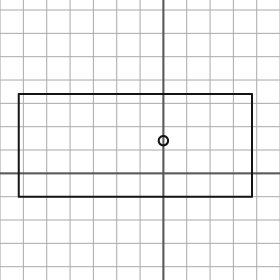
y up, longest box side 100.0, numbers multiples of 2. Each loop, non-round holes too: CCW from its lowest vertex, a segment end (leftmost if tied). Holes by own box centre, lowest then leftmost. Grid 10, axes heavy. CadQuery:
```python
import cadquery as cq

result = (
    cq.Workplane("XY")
    .moveTo(-62.0, -10.0)
    .lineTo(38.0, -10.0)
    .lineTo(38.0, 34.0)
    .lineTo(-62.0, 34.0)
    .close()
    .moveTo(0.0, 14.0)
    .circle(2.0)
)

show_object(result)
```